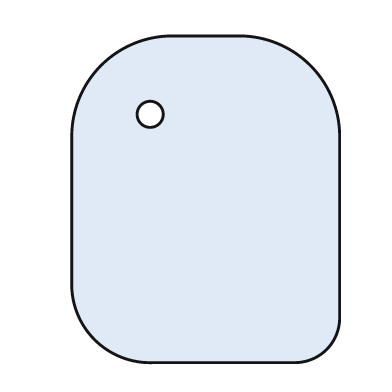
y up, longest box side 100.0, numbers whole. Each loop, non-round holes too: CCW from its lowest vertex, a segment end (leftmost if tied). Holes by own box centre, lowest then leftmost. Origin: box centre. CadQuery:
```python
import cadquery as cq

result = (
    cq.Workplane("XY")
    .moveTo(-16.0, -50.0)
    .lineTo(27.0, -50.0)
    .threePointArc((37.0, -46.0), (41.0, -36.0))
    .lineTo(41.0, 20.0)
    .threePointArc((32.0, 41.0), (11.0, 50.0))
    .lineTo(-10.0, 50.0)
    .threePointArc((-32.0, 41.0), (-41.0, 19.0))
    .lineTo(-41.0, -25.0)
    .threePointArc((-34.0, -43.0), (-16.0, -50.0))
    .close()
    .moveTo(-17.0, 26.0)
    .circle(4.0)
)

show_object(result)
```